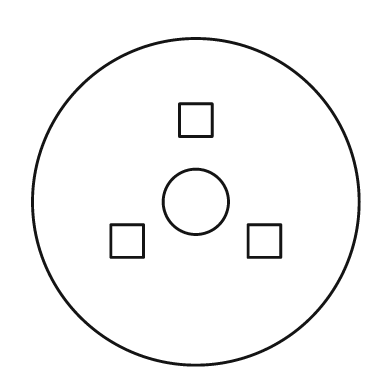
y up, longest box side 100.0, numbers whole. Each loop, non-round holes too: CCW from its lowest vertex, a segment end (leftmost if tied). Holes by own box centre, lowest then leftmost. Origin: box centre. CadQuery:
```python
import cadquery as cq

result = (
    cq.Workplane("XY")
    .moveTo(0.0, 0.0)
    .circle(50.0)
    .moveTo(-26.0, -17.0)
    .lineTo(-16.0, -17.0)
    .lineTo(-16.0, -7.0)
    .lineTo(-26.0, -7.0)
    .close()
    .moveTo(16.0, -17.0)
    .lineTo(26.0, -17.0)
    .lineTo(26.0, -7.0)
    .lineTo(16.0, -7.0)
    .close()
    .moveTo(0.0, 0.0)
    .circle(10.0)
    .moveTo(-5.0, 20.0)
    .lineTo(5.0, 20.0)
    .lineTo(5.0, 30.0)
    .lineTo(-5.0, 30.0)
    .close()
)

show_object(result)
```